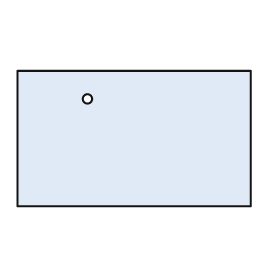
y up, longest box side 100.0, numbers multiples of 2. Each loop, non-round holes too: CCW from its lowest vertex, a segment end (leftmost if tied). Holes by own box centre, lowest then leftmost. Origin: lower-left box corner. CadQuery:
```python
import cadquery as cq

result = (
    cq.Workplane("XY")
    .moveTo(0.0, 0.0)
    .lineTo(100.0, 0.0)
    .lineTo(100.0, 58.0)
    .lineTo(0.0, 58.0)
    .close()
    .moveTo(30.0, 46.0)
    .circle(2.0)
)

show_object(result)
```